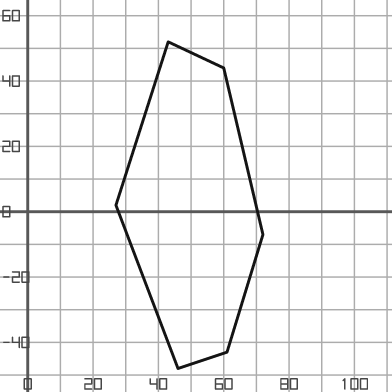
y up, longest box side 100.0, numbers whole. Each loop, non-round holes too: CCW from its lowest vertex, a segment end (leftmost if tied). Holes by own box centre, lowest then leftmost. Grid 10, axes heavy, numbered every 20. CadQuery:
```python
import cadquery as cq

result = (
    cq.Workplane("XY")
    .moveTo(46.0, -48.0)
    .lineTo(61.0, -43.0)
    .lineTo(72.0, -7.0)
    .lineTo(60.0, 44.0)
    .lineTo(43.0, 52.0)
    .lineTo(27.0, 2.0)
    .close()
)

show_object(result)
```